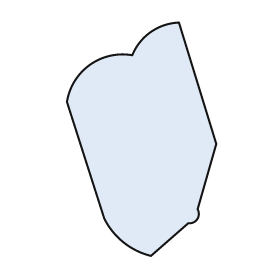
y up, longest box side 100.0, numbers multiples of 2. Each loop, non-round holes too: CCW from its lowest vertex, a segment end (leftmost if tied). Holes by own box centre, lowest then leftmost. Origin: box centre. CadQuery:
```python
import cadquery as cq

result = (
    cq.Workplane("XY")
    .moveTo(4.0, -50.0)
    .lineTo(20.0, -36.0)
    .threePointArc((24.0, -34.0), (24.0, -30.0))
    .lineTo(32.0, -2.0)
    .lineTo(16.0, 50.0)
    .threePointArc((4.0, 46.0), (-4.0, 36.0))
    .threePointArc((-22.0, 32.0), (-32.0, 16.0))
    .lineTo(-16.0, -34.0)
    .threePointArc((-8.0, -44.0), (4.0, -50.0))
    .close()
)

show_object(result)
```